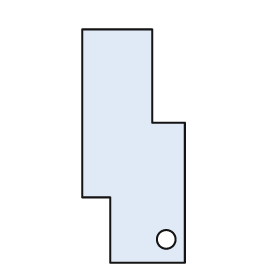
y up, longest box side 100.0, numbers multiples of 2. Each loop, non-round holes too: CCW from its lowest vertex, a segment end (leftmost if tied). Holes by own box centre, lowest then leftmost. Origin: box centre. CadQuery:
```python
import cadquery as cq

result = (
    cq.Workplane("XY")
    .moveTo(-10.0, -50.0)
    .lineTo(22.0, -50.0)
    .lineTo(22.0, 10.0)
    .lineTo(8.0, 10.0)
    .lineTo(8.0, 50.0)
    .lineTo(-22.0, 50.0)
    .lineTo(-22.0, -22.0)
    .lineTo(-10.0, -22.0)
    .close()
    .moveTo(14.0, -40.0)
    .circle(4.0)
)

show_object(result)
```